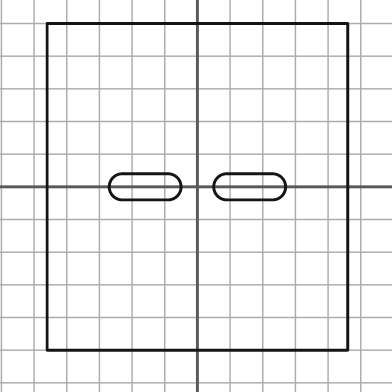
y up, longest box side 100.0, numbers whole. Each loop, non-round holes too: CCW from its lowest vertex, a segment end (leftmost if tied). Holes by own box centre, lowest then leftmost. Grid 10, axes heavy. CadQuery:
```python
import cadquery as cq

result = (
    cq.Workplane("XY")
    .moveTo(-46.0, -50.0)
    .lineTo(46.0, -50.0)
    .lineTo(46.0, 50.0)
    .lineTo(-46.0, 50.0)
    .close()
    .moveTo(-23.0, -4.0)
    .lineTo(-9.0, -4.0)
    .threePointArc((-5.0, 0.0), (-9.0, 4.0))
    .lineTo(-23.0, 4.0)
    .threePointArc((-27.0, 0.0), (-23.0, -4.0))
    .close()
    .moveTo(9.0, -4.0)
    .lineTo(23.0, -4.0)
    .threePointArc((27.0, 0.0), (23.0, 4.0))
    .lineTo(9.0, 4.0)
    .threePointArc((5.0, 0.0), (9.0, -4.0))
    .close()
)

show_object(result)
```